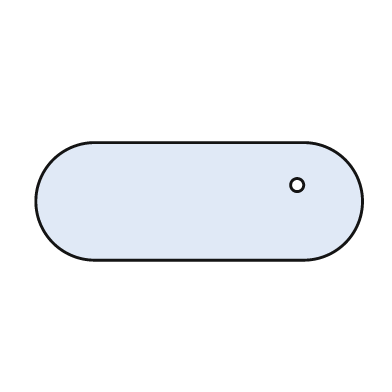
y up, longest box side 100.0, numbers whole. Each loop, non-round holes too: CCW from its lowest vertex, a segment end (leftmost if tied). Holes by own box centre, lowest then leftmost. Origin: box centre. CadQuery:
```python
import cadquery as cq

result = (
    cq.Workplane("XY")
    .moveTo(-32.0, -18.0)
    .lineTo(32.0, -18.0)
    .threePointArc((50.0, 0.0), (32.0, 18.0))
    .lineTo(-32.0, 18.0)
    .threePointArc((-50.0, 0.0), (-32.0, -18.0))
    .close()
    .moveTo(30.0, 5.0)
    .circle(2.0)
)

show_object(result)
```